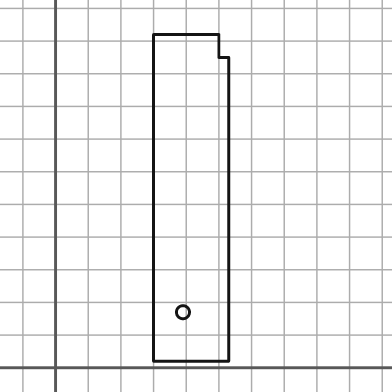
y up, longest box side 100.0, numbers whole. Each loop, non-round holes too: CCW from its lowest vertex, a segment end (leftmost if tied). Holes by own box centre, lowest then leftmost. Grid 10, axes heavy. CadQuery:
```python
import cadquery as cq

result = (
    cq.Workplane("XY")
    .moveTo(30.0, 2.0)
    .lineTo(53.0, 2.0)
    .lineTo(53.0, 95.0)
    .lineTo(50.0, 95.0)
    .lineTo(50.0, 102.0)
    .lineTo(30.0, 102.0)
    .close()
    .moveTo(39.0, 17.0)
    .circle(2.0)
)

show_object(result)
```